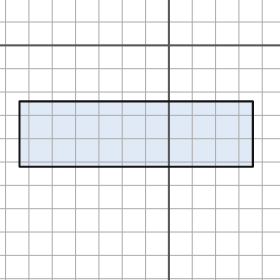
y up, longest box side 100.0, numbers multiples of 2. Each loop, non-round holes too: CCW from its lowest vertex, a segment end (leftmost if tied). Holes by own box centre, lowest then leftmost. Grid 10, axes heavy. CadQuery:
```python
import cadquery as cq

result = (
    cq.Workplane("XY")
    .moveTo(-64.0, -52.0)
    .lineTo(36.0, -52.0)
    .lineTo(36.0, -24.0)
    .lineTo(-64.0, -24.0)
    .close()
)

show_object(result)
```